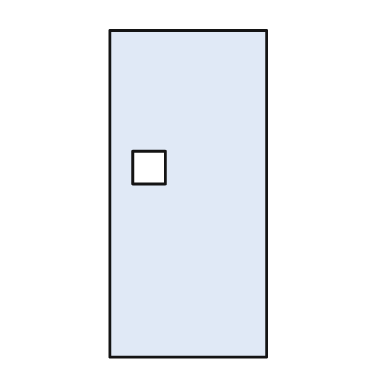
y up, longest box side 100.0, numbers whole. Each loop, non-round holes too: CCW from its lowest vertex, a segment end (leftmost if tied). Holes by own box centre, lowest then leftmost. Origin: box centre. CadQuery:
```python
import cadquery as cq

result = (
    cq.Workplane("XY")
    .moveTo(-24.0, -50.0)
    .lineTo(24.0, -50.0)
    .lineTo(24.0, 50.0)
    .lineTo(-24.0, 50.0)
    .close()
    .moveTo(-17.0, 3.0)
    .lineTo(-7.0, 3.0)
    .lineTo(-7.0, 13.0)
    .lineTo(-17.0, 13.0)
    .close()
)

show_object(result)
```